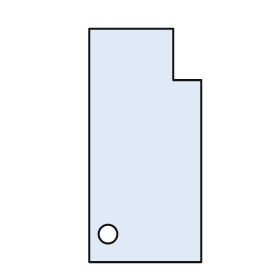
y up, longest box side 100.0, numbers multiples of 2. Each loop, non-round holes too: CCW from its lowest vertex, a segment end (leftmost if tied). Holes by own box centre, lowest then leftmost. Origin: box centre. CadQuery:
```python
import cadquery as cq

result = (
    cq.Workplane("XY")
    .moveTo(-24.0, -50.0)
    .lineTo(24.0, -50.0)
    .lineTo(24.0, 28.0)
    .lineTo(12.0, 28.0)
    .lineTo(12.0, 50.0)
    .lineTo(-24.0, 50.0)
    .close()
    .moveTo(-16.0, -38.0)
    .circle(4.0)
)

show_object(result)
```